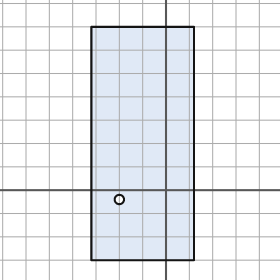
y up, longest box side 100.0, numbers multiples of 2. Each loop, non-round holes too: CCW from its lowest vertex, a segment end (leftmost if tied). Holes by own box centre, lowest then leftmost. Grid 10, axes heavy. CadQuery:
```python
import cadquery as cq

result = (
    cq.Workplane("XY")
    .moveTo(-32.0, -30.0)
    .lineTo(12.0, -30.0)
    .lineTo(12.0, 70.0)
    .lineTo(-32.0, 70.0)
    .close()
    .moveTo(-20.0, -4.0)
    .circle(2.0)
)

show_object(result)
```